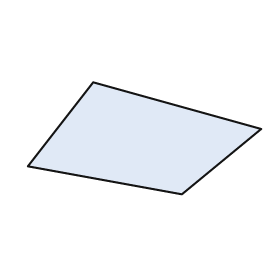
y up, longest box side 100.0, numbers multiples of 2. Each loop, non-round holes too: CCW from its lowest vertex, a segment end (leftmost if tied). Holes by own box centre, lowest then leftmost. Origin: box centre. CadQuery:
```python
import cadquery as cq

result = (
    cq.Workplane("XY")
    .moveTo(16.0, -24.0)
    .lineTo(50.0, 4.0)
    .lineTo(-22.0, 24.0)
    .lineTo(-50.0, -12.0)
    .close()
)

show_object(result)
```